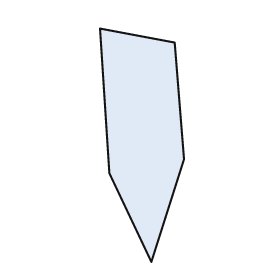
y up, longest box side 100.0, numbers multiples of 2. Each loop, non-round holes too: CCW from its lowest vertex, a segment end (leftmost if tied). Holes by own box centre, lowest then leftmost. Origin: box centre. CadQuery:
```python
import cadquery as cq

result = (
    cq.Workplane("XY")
    .moveTo(4.0, -50.0)
    .lineTo(18.0, -6.0)
    .lineTo(14.0, 44.0)
    .lineTo(-18.0, 50.0)
    .lineTo(-14.0, -12.0)
    .close()
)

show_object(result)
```